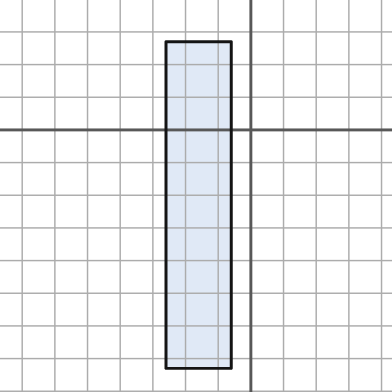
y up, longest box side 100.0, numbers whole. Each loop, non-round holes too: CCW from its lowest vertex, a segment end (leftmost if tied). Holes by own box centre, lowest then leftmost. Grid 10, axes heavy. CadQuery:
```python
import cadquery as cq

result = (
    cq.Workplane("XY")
    .moveTo(-26.0, -73.0)
    .lineTo(-6.0, -73.0)
    .lineTo(-6.0, 27.0)
    .lineTo(-26.0, 27.0)
    .close()
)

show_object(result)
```